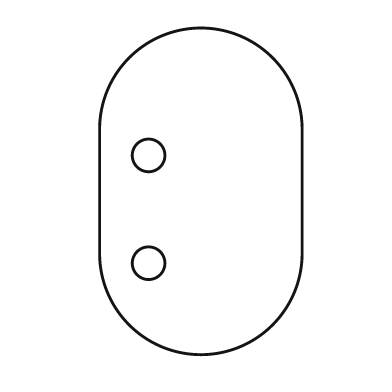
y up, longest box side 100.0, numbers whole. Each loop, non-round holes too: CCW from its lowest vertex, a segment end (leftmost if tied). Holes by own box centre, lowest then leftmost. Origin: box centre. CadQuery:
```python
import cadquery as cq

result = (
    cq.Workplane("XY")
    .moveTo(-31.0, -19.0)
    .threePointArc((0.0, -50.0), (31.0, -19.0))
    .lineTo(31.0, 19.0)
    .threePointArc((0.0, 50.0), (-31.0, 19.0))
    .close()
    .moveTo(-16.0, -22.0)
    .circle(5.0)
    .moveTo(-16.0, 11.0)
    .circle(5.0)
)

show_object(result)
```